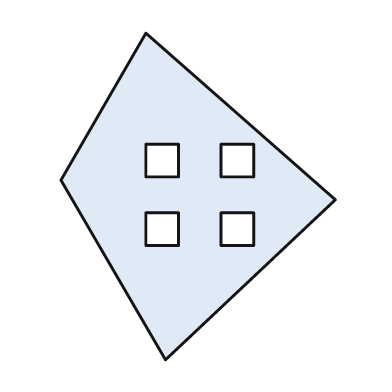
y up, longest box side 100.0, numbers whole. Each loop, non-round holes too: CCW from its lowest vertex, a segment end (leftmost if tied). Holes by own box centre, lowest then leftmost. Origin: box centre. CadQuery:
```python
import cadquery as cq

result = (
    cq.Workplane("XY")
    .moveTo(-10.0, -50.0)
    .lineTo(42.0, -1.0)
    .lineTo(-16.0, 50.0)
    .lineTo(-42.0, 5.0)
    .close()
    .moveTo(-16.0, -15.0)
    .lineTo(-6.0, -15.0)
    .lineTo(-6.0, -5.0)
    .lineTo(-16.0, -5.0)
    .close()
    .moveTo(7.0, -15.0)
    .lineTo(17.0, -15.0)
    .lineTo(17.0, -5.0)
    .lineTo(7.0, -5.0)
    .close()
    .moveTo(-16.0, 6.0)
    .lineTo(-6.0, 6.0)
    .lineTo(-6.0, 16.0)
    .lineTo(-16.0, 16.0)
    .close()
    .moveTo(7.0, 6.0)
    .lineTo(17.0, 6.0)
    .lineTo(17.0, 16.0)
    .lineTo(7.0, 16.0)
    .close()
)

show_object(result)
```